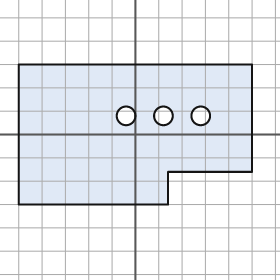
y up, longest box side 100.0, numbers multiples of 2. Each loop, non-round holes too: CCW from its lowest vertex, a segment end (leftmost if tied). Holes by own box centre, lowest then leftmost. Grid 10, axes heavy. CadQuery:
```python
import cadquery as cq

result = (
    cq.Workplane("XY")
    .moveTo(-50.0, -30.0)
    .lineTo(14.0, -30.0)
    .lineTo(14.0, -16.0)
    .lineTo(50.0, -16.0)
    .lineTo(50.0, 30.0)
    .lineTo(-50.0, 30.0)
    .close()
    .moveTo(-4.0, 8.0)
    .circle(4.0)
    .moveTo(12.0, 8.0)
    .circle(4.0)
    .moveTo(28.0, 8.0)
    .circle(4.0)
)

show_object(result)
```